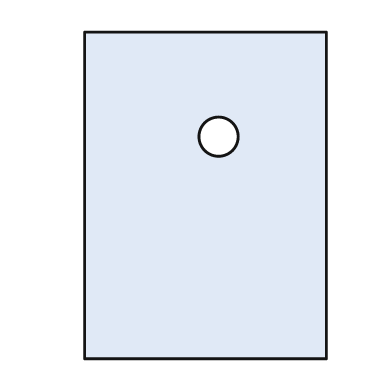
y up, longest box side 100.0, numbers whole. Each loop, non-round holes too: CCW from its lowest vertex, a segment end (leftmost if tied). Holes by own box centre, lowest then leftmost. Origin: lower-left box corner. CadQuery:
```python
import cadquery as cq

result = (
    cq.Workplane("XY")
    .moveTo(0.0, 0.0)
    .lineTo(74.0, 0.0)
    .lineTo(74.0, 100.0)
    .lineTo(0.0, 100.0)
    .close()
    .moveTo(41.0, 68.0)
    .circle(6.0)
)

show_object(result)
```